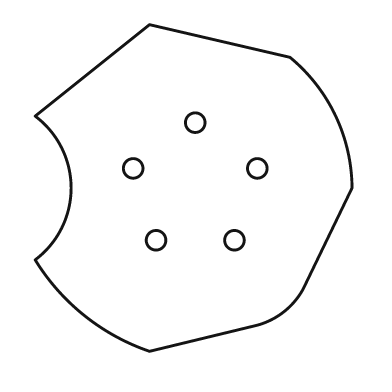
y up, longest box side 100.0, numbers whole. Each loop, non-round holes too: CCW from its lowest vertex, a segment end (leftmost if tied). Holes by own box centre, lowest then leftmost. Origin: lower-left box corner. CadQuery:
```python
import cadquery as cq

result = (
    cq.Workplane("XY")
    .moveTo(35.0, 0.0)
    .lineTo(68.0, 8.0)
    .threePointArc((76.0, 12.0), (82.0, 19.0))
    .lineTo(97.0, 50.0)
    .threePointArc((92.0, 72.0), (78.0, 90.0))
    .lineTo(35.0, 100.0)
    .lineTo(0.0, 72.0)
    .threePointArc((11.0, 50.0), (0.0, 28.0))
    .threePointArc((15.0, 11.0), (35.0, 0.0))
    .close()
    .moveTo(37.0, 34.0)
    .circle(3.0)
    .moveTo(61.0, 34.0)
    .circle(3.0)
    .moveTo(30.0, 56.0)
    .circle(3.0)
    .moveTo(68.0, 56.0)
    .circle(3.0)
    .moveTo(49.0, 70.0)
    .circle(3.0)
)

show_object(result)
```